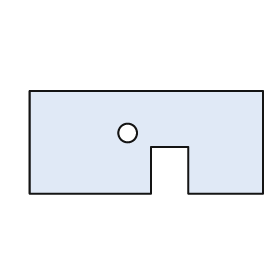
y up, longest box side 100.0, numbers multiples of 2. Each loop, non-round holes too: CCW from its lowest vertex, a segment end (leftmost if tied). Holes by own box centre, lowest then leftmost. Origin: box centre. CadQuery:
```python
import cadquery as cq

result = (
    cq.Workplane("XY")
    .moveTo(-50.0, -22.0)
    .lineTo(2.0, -22.0)
    .lineTo(2.0, -2.0)
    .lineTo(18.0, -2.0)
    .lineTo(18.0, -22.0)
    .lineTo(50.0, -22.0)
    .lineTo(50.0, 22.0)
    .lineTo(-50.0, 22.0)
    .close()
    .moveTo(-8.0, 4.0)
    .circle(4.0)
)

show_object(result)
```